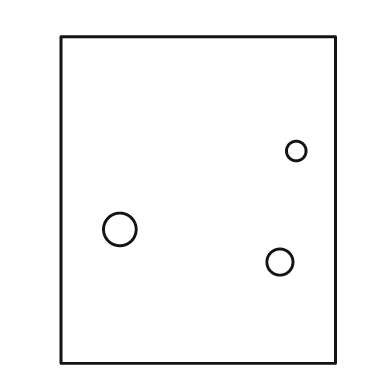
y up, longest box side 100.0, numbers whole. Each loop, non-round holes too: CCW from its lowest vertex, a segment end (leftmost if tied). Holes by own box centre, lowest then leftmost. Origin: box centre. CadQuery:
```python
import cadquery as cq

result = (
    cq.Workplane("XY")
    .moveTo(-42.0, -50.0)
    .lineTo(42.0, -50.0)
    .lineTo(42.0, 50.0)
    .lineTo(-42.0, 50.0)
    .close()
    .moveTo(25.0, -19.0)
    .circle(4.0)
    .moveTo(-24.0, -9.0)
    .circle(5.0)
    .moveTo(30.0, 15.0)
    .circle(3.0)
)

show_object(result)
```